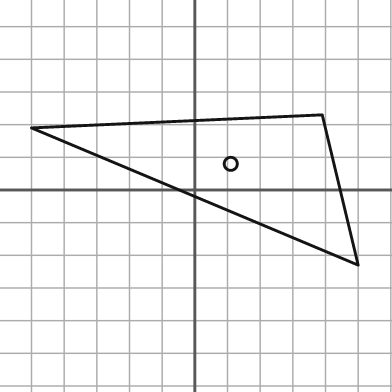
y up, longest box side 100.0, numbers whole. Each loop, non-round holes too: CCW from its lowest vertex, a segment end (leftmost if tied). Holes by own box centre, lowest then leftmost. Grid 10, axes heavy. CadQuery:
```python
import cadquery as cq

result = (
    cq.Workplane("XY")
    .moveTo(50.0, -23.0)
    .lineTo(39.0, 23.0)
    .lineTo(-50.0, 19.0)
    .close()
    .moveTo(11.0, 8.0)
    .circle(2.0)
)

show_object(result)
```